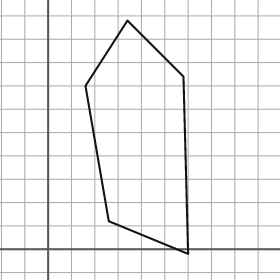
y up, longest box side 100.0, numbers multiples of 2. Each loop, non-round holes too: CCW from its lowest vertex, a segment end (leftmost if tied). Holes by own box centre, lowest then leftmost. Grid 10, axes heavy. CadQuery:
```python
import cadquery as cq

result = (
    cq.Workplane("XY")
    .moveTo(60.0, -2.0)
    .lineTo(58.0, 74.0)
    .lineTo(34.0, 98.0)
    .lineTo(16.0, 70.0)
    .lineTo(26.0, 12.0)
    .close()
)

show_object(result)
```